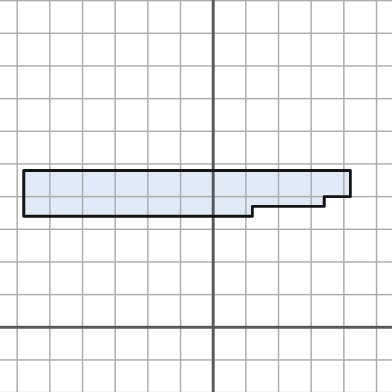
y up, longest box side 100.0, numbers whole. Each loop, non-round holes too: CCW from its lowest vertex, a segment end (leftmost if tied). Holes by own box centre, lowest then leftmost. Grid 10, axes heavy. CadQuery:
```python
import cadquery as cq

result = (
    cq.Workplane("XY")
    .moveTo(-58.0, 34.0)
    .lineTo(12.0, 34.0)
    .lineTo(12.0, 37.0)
    .lineTo(34.0, 37.0)
    .lineTo(34.0, 40.0)
    .lineTo(42.0, 40.0)
    .lineTo(42.0, 48.0)
    .lineTo(-58.0, 48.0)
    .close()
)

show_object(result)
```